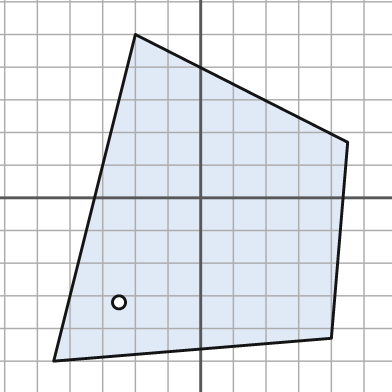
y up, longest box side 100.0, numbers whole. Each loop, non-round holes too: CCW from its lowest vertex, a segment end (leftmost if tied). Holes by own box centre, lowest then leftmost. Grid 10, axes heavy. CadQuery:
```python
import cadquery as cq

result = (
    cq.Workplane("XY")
    .moveTo(-45.0, -50.0)
    .lineTo(40.0, -43.0)
    .lineTo(45.0, 17.0)
    .lineTo(-20.0, 50.0)
    .close()
    .moveTo(-25.0, -32.0)
    .circle(2.0)
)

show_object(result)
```